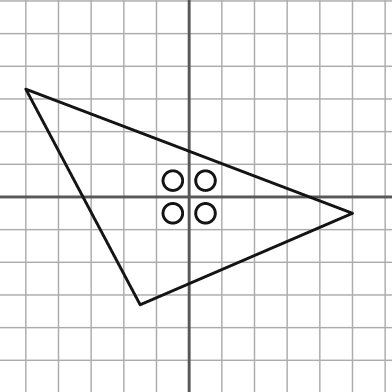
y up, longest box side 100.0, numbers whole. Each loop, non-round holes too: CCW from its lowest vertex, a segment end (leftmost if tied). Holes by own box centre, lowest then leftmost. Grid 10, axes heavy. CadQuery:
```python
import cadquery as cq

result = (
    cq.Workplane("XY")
    .moveTo(-15.0, -33.0)
    .lineTo(50.0, -5.0)
    .lineTo(-50.0, 33.0)
    .close()
    .moveTo(-5.0, -5.0)
    .circle(3.0)
    .moveTo(5.0, -5.0)
    .circle(3.0)
    .moveTo(-5.0, 5.0)
    .circle(3.0)
    .moveTo(5.0, 5.0)
    .circle(3.0)
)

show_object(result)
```